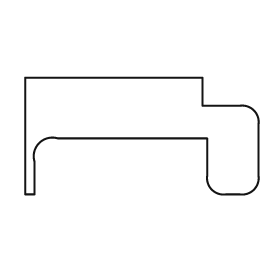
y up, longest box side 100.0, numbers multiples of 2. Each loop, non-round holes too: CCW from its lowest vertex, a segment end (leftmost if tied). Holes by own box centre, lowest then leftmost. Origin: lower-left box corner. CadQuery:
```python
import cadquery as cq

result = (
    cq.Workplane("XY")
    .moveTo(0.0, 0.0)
    .lineTo(4.0, 0.0)
    .lineTo(4.0, 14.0)
    .threePointArc((6.0, 22.0), (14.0, 24.0))
    .lineTo(78.0, 24.0)
    .lineTo(78.0, 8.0)
    .threePointArc((80.0, 2.0), (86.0, 0.0))
    .lineTo(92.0, 0.0)
    .threePointArc((98.0, 2.0), (100.0, 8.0))
    .lineTo(100.0, 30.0)
    .threePointArc((98.0, 36.0), (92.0, 38.0))
    .lineTo(76.0, 38.0)
    .lineTo(76.0, 50.0)
    .lineTo(0.0, 50.0)
    .close()
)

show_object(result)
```